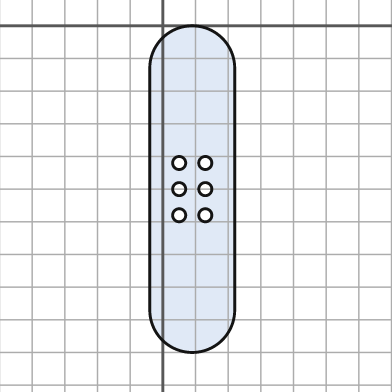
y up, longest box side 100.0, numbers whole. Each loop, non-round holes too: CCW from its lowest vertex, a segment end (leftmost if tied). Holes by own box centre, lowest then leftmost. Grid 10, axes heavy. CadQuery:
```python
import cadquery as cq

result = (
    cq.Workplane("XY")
    .moveTo(-4.0, -87.0)
    .threePointArc((9.0, -100.0), (22.0, -87.0))
    .lineTo(22.0, -13.0)
    .threePointArc((9.0, 0.0), (-4.0, -13.0))
    .close()
    .moveTo(5.0, -58.0)
    .circle(2.0)
    .moveTo(13.0, -58.0)
    .circle(2.0)
    .moveTo(5.0, -50.0)
    .circle(2.0)
    .moveTo(13.0, -50.0)
    .circle(2.0)
    .moveTo(5.0, -42.0)
    .circle(2.0)
    .moveTo(13.0, -42.0)
    .circle(2.0)
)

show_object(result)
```